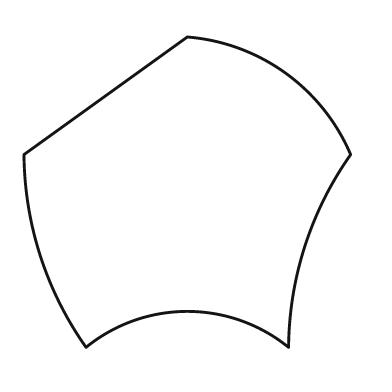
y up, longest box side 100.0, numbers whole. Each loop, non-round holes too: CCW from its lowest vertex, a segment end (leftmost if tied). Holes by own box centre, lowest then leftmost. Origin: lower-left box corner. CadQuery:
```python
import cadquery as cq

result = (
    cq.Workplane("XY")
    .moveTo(19.0, 0.0)
    .threePointArc((50.0, 11.0), (81.0, 0.0))
    .threePointArc((86.0, 31.0), (100.0, 59.0))
    .threePointArc((80.0, 84.0), (50.0, 95.0))
    .lineTo(0.0, 59.0)
    .threePointArc((5.0, 28.0), (19.0, 0.0))
    .close()
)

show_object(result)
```